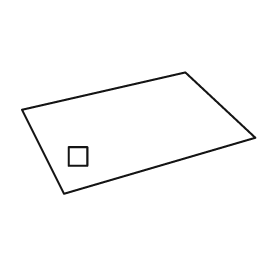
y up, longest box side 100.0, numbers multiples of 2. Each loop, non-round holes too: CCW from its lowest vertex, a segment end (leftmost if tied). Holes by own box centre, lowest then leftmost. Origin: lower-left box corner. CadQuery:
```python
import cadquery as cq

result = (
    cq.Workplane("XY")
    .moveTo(18.0, 0.0)
    .lineTo(100.0, 24.0)
    .lineTo(70.0, 52.0)
    .lineTo(0.0, 36.0)
    .close()
    .moveTo(20.0, 12.0)
    .lineTo(28.0, 12.0)
    .lineTo(28.0, 20.0)
    .lineTo(20.0, 20.0)
    .close()
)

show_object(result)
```